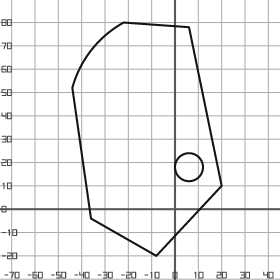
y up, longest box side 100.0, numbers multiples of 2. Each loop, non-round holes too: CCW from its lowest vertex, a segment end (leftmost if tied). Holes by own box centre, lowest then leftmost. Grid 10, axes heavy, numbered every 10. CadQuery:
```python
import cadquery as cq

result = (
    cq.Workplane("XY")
    .moveTo(-8.0, -20.0)
    .lineTo(20.0, 10.0)
    .lineTo(6.0, 78.0)
    .lineTo(-22.0, 80.0)
    .threePointArc((-36.0, 68.0), (-44.0, 52.0))
    .lineTo(-36.0, -4.0)
    .close()
    .moveTo(6.0, 18.0)
    .circle(6.0)
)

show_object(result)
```